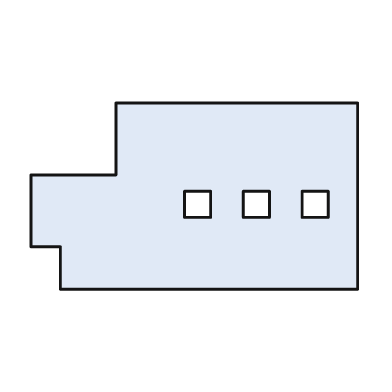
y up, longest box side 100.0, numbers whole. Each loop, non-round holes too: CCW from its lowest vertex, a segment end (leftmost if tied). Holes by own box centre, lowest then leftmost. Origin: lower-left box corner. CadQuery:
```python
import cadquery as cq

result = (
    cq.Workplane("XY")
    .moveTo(9.0, 0.0)
    .lineTo(100.0, 0.0)
    .lineTo(100.0, 57.0)
    .lineTo(26.0, 57.0)
    .lineTo(26.0, 35.0)
    .lineTo(0.0, 35.0)
    .lineTo(0.0, 13.0)
    .lineTo(9.0, 13.0)
    .close()
    .moveTo(47.0, 22.0)
    .lineTo(55.0, 22.0)
    .lineTo(55.0, 30.0)
    .lineTo(47.0, 30.0)
    .close()
    .moveTo(65.0, 22.0)
    .lineTo(73.0, 22.0)
    .lineTo(73.0, 30.0)
    .lineTo(65.0, 30.0)
    .close()
    .moveTo(83.0, 22.0)
    .lineTo(91.0, 22.0)
    .lineTo(91.0, 30.0)
    .lineTo(83.0, 30.0)
    .close()
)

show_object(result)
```